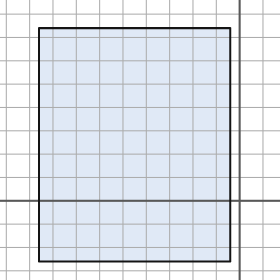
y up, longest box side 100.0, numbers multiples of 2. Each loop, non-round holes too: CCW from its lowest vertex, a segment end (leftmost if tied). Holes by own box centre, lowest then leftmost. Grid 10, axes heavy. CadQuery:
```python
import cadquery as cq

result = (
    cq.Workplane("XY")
    .moveTo(-86.0, -26.0)
    .lineTo(-4.0, -26.0)
    .lineTo(-4.0, 74.0)
    .lineTo(-86.0, 74.0)
    .close()
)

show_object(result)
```